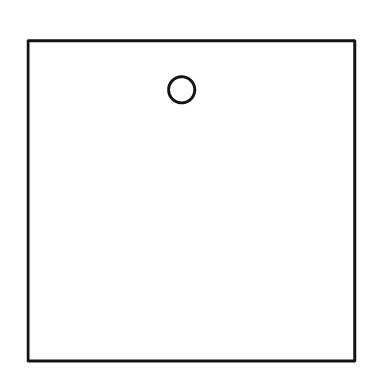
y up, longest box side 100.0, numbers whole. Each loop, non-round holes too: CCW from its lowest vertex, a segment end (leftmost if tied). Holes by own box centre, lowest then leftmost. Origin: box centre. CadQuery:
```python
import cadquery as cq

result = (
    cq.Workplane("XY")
    .moveTo(-50.0, -49.0)
    .lineTo(50.0, -49.0)
    .lineTo(50.0, 49.0)
    .lineTo(-50.0, 49.0)
    .close()
    .moveTo(-3.0, 34.0)
    .circle(4.0)
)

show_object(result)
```